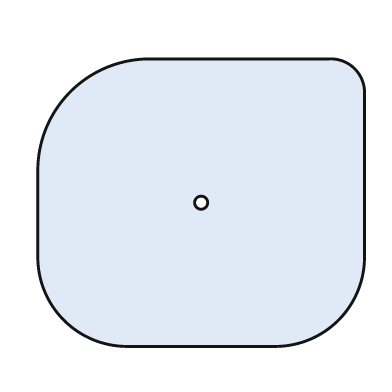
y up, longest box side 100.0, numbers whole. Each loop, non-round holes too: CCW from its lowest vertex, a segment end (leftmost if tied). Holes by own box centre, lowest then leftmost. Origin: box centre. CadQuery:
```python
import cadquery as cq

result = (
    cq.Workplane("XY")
    .moveTo(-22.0, -44.0)
    .lineTo(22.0, -44.0)
    .threePointArc((42.0, -36.0), (50.0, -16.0))
    .lineTo(50.0, 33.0)
    .threePointArc((47.0, 41.0), (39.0, 44.0))
    .lineTo(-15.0, 44.0)
    .threePointArc((-40.0, 34.0), (-50.0, 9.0))
    .lineTo(-50.0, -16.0)
    .threePointArc((-42.0, -36.0), (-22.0, -44.0))
    .close()
    .moveTo(0.0, 0.0)
    .circle(2.0)
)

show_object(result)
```